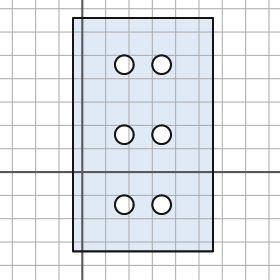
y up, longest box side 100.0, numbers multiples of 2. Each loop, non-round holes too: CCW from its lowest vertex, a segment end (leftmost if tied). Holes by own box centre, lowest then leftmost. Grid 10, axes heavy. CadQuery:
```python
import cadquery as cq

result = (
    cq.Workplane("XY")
    .moveTo(-4.0, -34.0)
    .lineTo(56.0, -34.0)
    .lineTo(56.0, 66.0)
    .lineTo(-4.0, 66.0)
    .close()
    .moveTo(18.0, -14.0)
    .circle(4.0)
    .moveTo(34.0, -14.0)
    .circle(4.0)
    .moveTo(18.0, 16.0)
    .circle(4.0)
    .moveTo(34.0, 16.0)
    .circle(4.0)
    .moveTo(18.0, 46.0)
    .circle(4.0)
    .moveTo(34.0, 46.0)
    .circle(4.0)
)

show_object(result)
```